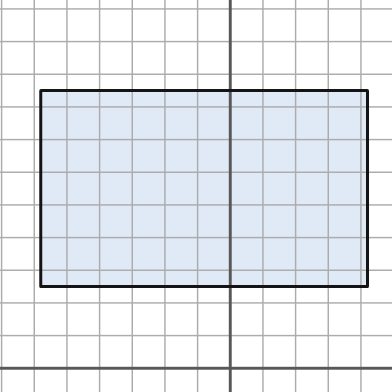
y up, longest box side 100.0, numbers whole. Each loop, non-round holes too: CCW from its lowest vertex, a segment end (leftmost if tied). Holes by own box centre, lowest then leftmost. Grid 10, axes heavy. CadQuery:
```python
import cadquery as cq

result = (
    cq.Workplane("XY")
    .moveTo(-58.0, 25.0)
    .lineTo(42.0, 25.0)
    .lineTo(42.0, 85.0)
    .lineTo(-58.0, 85.0)
    .close()
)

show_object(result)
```